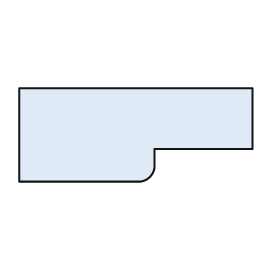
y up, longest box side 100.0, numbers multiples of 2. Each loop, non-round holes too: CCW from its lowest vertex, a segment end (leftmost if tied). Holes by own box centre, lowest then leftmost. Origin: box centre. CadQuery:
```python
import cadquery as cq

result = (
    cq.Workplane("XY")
    .moveTo(-50.0, -20.0)
    .lineTo(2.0, -20.0)
    .threePointArc((6.0, -18.0), (8.0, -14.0))
    .lineTo(8.0, -6.0)
    .lineTo(50.0, -6.0)
    .lineTo(50.0, 20.0)
    .lineTo(-50.0, 20.0)
    .close()
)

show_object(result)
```